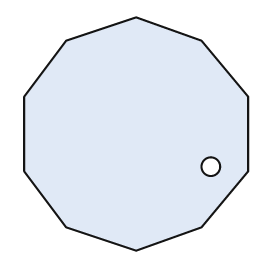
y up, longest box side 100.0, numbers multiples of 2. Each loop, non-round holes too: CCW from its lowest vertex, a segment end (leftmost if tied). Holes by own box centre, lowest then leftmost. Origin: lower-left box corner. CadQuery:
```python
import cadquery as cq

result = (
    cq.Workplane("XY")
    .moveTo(48.0, 0.0)
    .lineTo(76.0, 10.0)
    .lineTo(96.0, 34.0)
    .lineTo(96.0, 66.0)
    .lineTo(76.0, 90.0)
    .lineTo(48.0, 100.0)
    .lineTo(18.0, 90.0)
    .lineTo(0.0, 66.0)
    .lineTo(0.0, 34.0)
    .lineTo(18.0, 10.0)
    .close()
    .moveTo(80.0, 36.0)
    .circle(4.0)
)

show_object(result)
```